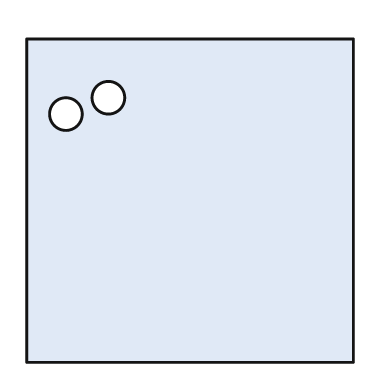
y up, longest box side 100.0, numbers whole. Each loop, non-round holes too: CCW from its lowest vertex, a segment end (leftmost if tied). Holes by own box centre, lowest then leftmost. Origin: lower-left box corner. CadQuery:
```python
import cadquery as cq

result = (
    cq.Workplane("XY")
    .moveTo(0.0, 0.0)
    .lineTo(100.0, 0.0)
    .lineTo(100.0, 99.0)
    .lineTo(0.0, 99.0)
    .close()
    .moveTo(12.0, 76.0)
    .circle(5.0)
    .moveTo(25.0, 81.0)
    .circle(5.0)
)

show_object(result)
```